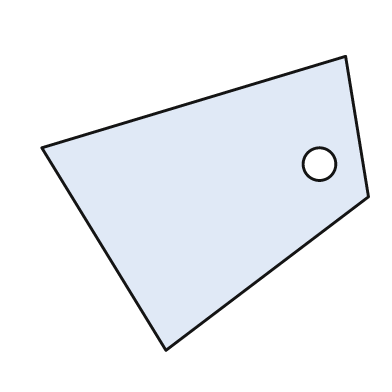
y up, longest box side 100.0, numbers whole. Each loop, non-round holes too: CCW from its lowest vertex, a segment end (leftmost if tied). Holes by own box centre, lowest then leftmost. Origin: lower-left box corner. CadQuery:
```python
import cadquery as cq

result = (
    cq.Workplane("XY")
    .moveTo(38.0, 0.0)
    .lineTo(100.0, 47.0)
    .lineTo(93.0, 90.0)
    .lineTo(0.0, 62.0)
    .close()
    .moveTo(85.0, 57.0)
    .circle(5.0)
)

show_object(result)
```